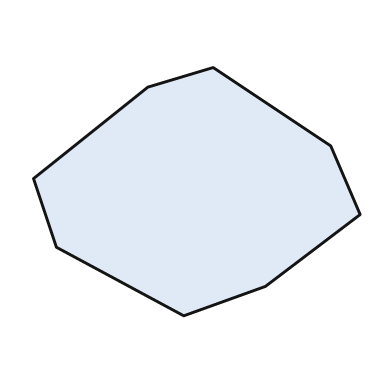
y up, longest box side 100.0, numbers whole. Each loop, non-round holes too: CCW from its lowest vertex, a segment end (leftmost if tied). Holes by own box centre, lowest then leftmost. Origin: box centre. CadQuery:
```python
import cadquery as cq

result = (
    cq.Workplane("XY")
    .moveTo(-4.0, -38.0)
    .lineTo(21.0, -29.0)
    .lineTo(50.0, -7.0)
    .lineTo(41.0, 14.0)
    .lineTo(5.0, 38.0)
    .lineTo(-15.0, 32.0)
    .lineTo(-50.0, 4.0)
    .lineTo(-43.0, -17.0)
    .close()
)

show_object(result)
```